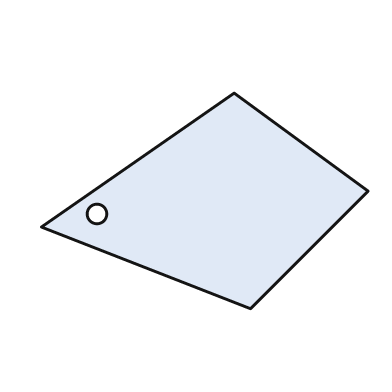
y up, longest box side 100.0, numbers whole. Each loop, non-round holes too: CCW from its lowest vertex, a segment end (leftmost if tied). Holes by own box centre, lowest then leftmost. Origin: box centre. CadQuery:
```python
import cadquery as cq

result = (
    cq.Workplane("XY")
    .moveTo(14.0, -33.0)
    .lineTo(50.0, 3.0)
    .lineTo(9.0, 33.0)
    .lineTo(-50.0, -8.0)
    .close()
    .moveTo(-33.0, -4.0)
    .circle(3.0)
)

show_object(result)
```